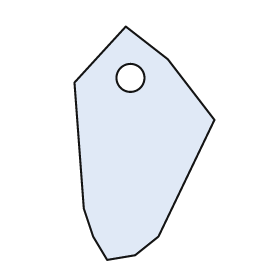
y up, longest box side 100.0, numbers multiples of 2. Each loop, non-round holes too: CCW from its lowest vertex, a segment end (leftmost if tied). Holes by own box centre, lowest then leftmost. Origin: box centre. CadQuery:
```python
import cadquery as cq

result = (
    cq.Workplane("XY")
    .moveTo(-16.0, -50.0)
    .lineTo(-4.0, -48.0)
    .lineTo(6.0, -40.0)
    .lineTo(30.0, 10.0)
    .lineTo(10.0, 36.0)
    .lineTo(-8.0, 50.0)
    .lineTo(-30.0, 26.0)
    .lineTo(-26.0, -28.0)
    .lineTo(-22.0, -40.0)
    .close()
    .moveTo(-6.0, 28.0)
    .circle(6.0)
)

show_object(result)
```